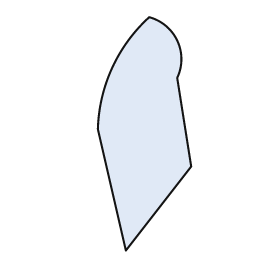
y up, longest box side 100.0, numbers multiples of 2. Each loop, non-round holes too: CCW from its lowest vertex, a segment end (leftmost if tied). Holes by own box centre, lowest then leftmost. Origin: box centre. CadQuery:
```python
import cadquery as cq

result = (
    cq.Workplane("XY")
    .moveTo(-8.0, -50.0)
    .lineTo(20.0, -14.0)
    .lineTo(14.0, 24.0)
    .threePointArc((14.0, 40.0), (2.0, 50.0))
    .threePointArc((-14.0, 28.0), (-20.0, 2.0))
    .close()
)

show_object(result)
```